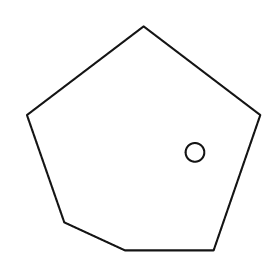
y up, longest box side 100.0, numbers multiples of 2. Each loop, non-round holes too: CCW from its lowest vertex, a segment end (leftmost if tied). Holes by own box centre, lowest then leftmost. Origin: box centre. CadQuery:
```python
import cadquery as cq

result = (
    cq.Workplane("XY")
    .moveTo(-8.0, -48.0)
    .lineTo(30.0, -48.0)
    .lineTo(50.0, 10.0)
    .lineTo(0.0, 48.0)
    .lineTo(-50.0, 10.0)
    .lineTo(-34.0, -36.0)
    .close()
    .moveTo(22.0, -6.0)
    .circle(4.0)
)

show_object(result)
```